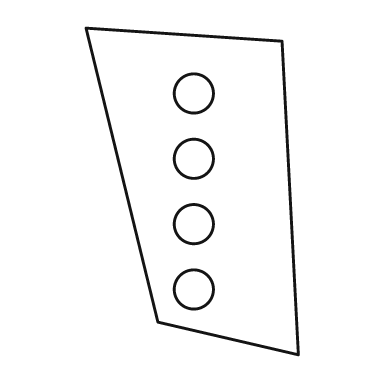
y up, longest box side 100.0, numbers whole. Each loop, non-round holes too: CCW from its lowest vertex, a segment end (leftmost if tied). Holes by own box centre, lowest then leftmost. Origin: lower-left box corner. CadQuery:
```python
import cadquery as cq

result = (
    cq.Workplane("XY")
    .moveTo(65.0, 0.0)
    .lineTo(60.0, 96.0)
    .lineTo(0.0, 100.0)
    .lineTo(22.0, 10.0)
    .close()
    .moveTo(33.0, 20.0)
    .circle(6.0)
    .moveTo(33.0, 40.0)
    .circle(6.0)
    .moveTo(33.0, 60.0)
    .circle(6.0)
    .moveTo(33.0, 80.0)
    .circle(6.0)
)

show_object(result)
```